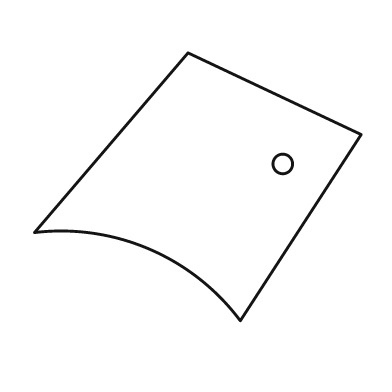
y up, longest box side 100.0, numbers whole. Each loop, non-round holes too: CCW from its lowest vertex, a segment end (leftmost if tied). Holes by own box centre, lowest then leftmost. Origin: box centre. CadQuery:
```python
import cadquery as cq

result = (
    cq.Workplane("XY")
    .moveTo(13.0, -41.0)
    .lineTo(50.0, 16.0)
    .lineTo(-3.0, 41.0)
    .lineTo(-50.0, -14.0)
    .threePointArc((-15.0, -19.0), (13.0, -41.0))
    .close()
    .moveTo(26.0, 7.0)
    .circle(3.0)
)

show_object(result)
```